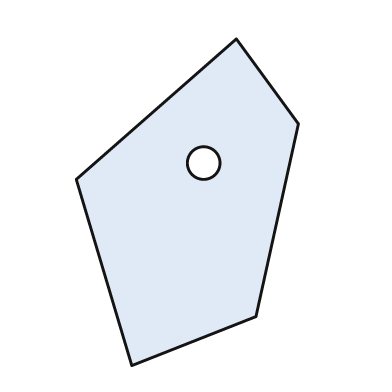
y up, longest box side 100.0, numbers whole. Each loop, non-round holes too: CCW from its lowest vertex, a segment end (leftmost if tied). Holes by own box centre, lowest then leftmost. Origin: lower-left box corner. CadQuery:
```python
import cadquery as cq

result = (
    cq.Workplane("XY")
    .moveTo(17.0, 0.0)
    .lineTo(55.0, 15.0)
    .lineTo(68.0, 74.0)
    .lineTo(49.0, 100.0)
    .lineTo(0.0, 57.0)
    .close()
    .moveTo(39.0, 62.0)
    .circle(5.0)
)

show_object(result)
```